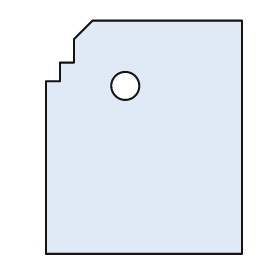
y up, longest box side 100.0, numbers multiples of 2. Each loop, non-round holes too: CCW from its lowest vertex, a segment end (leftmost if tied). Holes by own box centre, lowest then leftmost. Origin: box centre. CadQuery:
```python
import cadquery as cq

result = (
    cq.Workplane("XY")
    .moveTo(-42.0, -50.0)
    .lineTo(42.0, -50.0)
    .lineTo(42.0, 50.0)
    .lineTo(-22.0, 50.0)
    .lineTo(-30.0, 42.0)
    .lineTo(-30.0, 32.0)
    .lineTo(-36.0, 32.0)
    .lineTo(-36.0, 24.0)
    .lineTo(-42.0, 24.0)
    .close()
    .moveTo(-8.0, 22.0)
    .circle(6.0)
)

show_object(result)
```